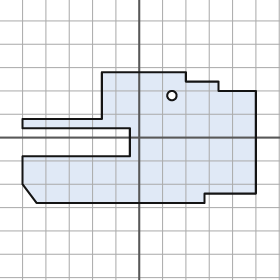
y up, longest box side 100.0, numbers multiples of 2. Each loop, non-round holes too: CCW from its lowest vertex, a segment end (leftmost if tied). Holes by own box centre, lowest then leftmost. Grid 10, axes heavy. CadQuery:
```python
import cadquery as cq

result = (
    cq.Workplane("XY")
    .moveTo(-44.0, -28.0)
    .lineTo(28.0, -28.0)
    .lineTo(28.0, -24.0)
    .lineTo(50.0, -24.0)
    .lineTo(50.0, 20.0)
    .lineTo(34.0, 20.0)
    .lineTo(34.0, 24.0)
    .lineTo(20.0, 24.0)
    .lineTo(20.0, 28.0)
    .lineTo(-16.0, 28.0)
    .lineTo(-16.0, 8.0)
    .lineTo(-50.0, 8.0)
    .lineTo(-50.0, 4.0)
    .lineTo(-4.0, 4.0)
    .lineTo(-4.0, -8.0)
    .lineTo(-50.0, -8.0)
    .lineTo(-50.0, -20.0)
    .close()
    .moveTo(14.0, 18.0)
    .circle(2.0)
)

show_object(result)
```